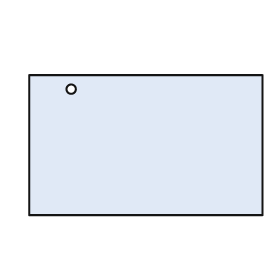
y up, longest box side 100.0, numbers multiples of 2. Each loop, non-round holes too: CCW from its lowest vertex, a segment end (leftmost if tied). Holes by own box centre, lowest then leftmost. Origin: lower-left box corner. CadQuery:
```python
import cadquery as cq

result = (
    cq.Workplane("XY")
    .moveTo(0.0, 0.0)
    .lineTo(100.0, 0.0)
    .lineTo(100.0, 60.0)
    .lineTo(0.0, 60.0)
    .close()
    .moveTo(18.0, 54.0)
    .circle(2.0)
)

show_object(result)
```